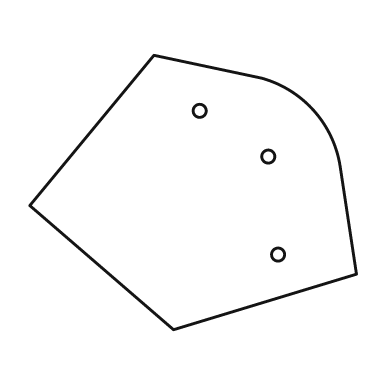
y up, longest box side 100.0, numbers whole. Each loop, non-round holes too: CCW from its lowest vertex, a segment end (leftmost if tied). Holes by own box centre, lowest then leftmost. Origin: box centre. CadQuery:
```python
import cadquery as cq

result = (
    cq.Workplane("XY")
    .moveTo(-6.0, -42.0)
    .lineTo(50.0, -25.0)
    .lineTo(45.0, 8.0)
    .threePointArc((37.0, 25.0), (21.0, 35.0))
    .lineTo(-12.0, 42.0)
    .lineTo(-50.0, -4.0)
    .close()
    .moveTo(26.0, -19.0)
    .circle(2.0)
    .moveTo(23.0, 11.0)
    .circle(2.0)
    .moveTo(2.0, 25.0)
    .circle(2.0)
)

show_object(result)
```